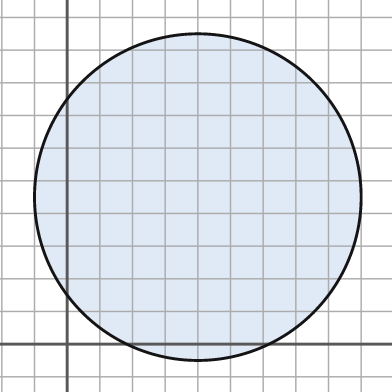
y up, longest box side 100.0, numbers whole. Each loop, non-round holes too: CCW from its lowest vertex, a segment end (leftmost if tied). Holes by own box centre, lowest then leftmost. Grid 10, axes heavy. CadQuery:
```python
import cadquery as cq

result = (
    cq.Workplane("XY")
    .moveTo(40.0, 45.0)
    .circle(50.0)
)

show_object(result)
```